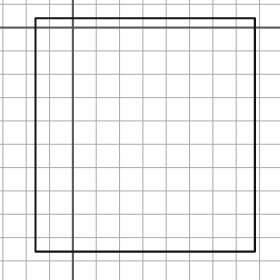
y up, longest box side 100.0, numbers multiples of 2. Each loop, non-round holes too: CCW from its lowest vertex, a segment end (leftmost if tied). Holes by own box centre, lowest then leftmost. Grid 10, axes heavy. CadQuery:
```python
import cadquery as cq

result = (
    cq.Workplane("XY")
    .moveTo(-16.0, -96.0)
    .lineTo(78.0, -96.0)
    .lineTo(78.0, 4.0)
    .lineTo(-16.0, 4.0)
    .close()
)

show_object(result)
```